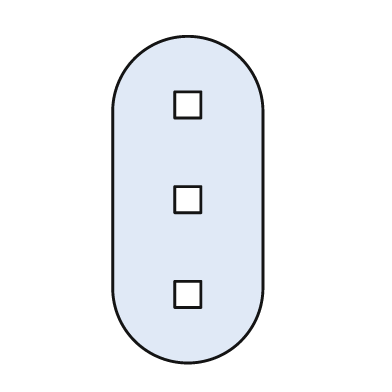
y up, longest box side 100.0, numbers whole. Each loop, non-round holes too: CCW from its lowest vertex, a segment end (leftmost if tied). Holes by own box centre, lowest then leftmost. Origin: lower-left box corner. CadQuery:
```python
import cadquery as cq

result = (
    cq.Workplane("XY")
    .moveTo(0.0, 23.0)
    .threePointArc((23.0, 0.0), (46.0, 23.0))
    .lineTo(46.0, 77.0)
    .threePointArc((23.0, 100.0), (0.0, 77.0))
    .close()
    .moveTo(19.0, 17.0)
    .lineTo(27.0, 17.0)
    .lineTo(27.0, 25.0)
    .lineTo(19.0, 25.0)
    .close()
    .moveTo(19.0, 46.0)
    .lineTo(27.0, 46.0)
    .lineTo(27.0, 54.0)
    .lineTo(19.0, 54.0)
    .close()
    .moveTo(19.0, 75.0)
    .lineTo(27.0, 75.0)
    .lineTo(27.0, 83.0)
    .lineTo(19.0, 83.0)
    .close()
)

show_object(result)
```